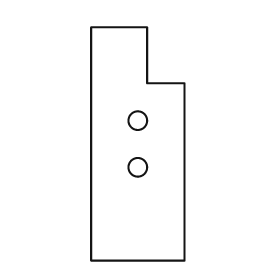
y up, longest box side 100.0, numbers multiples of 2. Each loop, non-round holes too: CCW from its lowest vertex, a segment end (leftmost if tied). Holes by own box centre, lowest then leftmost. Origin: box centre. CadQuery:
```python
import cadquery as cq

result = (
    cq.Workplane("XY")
    .moveTo(-20.0, -50.0)
    .lineTo(20.0, -50.0)
    .lineTo(20.0, 26.0)
    .lineTo(4.0, 26.0)
    .lineTo(4.0, 50.0)
    .lineTo(-20.0, 50.0)
    .close()
    .moveTo(0.0, -10.0)
    .circle(4.0)
    .moveTo(0.0, 10.0)
    .circle(4.0)
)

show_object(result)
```